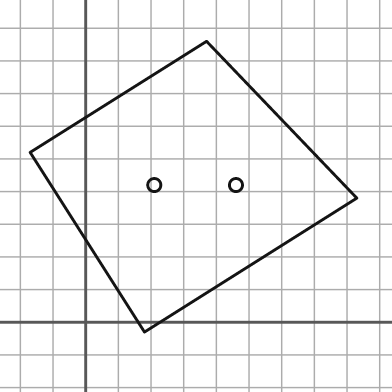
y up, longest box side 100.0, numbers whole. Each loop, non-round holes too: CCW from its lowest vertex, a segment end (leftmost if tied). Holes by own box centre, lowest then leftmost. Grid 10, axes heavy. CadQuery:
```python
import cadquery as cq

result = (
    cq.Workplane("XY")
    .moveTo(18.0, -3.0)
    .lineTo(83.0, 38.0)
    .lineTo(37.0, 86.0)
    .lineTo(-17.0, 52.0)
    .close()
    .moveTo(21.0, 42.0)
    .circle(2.0)
    .moveTo(46.0, 42.0)
    .circle(2.0)
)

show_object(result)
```